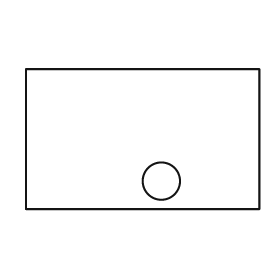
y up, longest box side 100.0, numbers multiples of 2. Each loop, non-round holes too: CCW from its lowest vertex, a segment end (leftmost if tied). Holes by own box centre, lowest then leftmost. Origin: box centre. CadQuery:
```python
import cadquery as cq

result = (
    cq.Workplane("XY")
    .moveTo(-50.0, -30.0)
    .lineTo(50.0, -30.0)
    .lineTo(50.0, 30.0)
    .lineTo(-50.0, 30.0)
    .close()
    .moveTo(8.0, -18.0)
    .circle(8.0)
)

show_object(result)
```